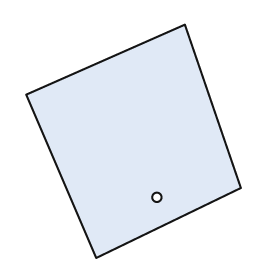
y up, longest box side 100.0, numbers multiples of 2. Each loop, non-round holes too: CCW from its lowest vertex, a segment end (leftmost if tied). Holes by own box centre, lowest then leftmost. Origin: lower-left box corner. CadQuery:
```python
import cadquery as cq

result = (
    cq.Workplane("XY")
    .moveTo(30.0, 0.0)
    .lineTo(92.0, 30.0)
    .lineTo(68.0, 100.0)
    .lineTo(0.0, 70.0)
    .close()
    .moveTo(56.0, 26.0)
    .circle(2.0)
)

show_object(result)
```